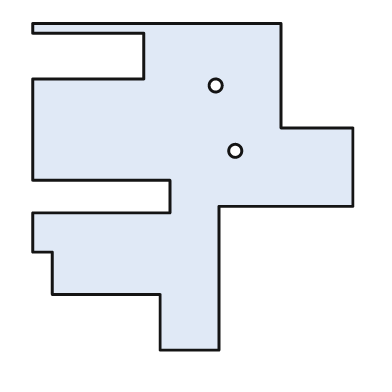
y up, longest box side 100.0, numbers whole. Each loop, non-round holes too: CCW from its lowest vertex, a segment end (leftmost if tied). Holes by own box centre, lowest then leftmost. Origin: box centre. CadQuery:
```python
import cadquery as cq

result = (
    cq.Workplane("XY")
    .moveTo(-10.0, -50.0)
    .lineTo(8.0, -50.0)
    .lineTo(8.0, -6.0)
    .lineTo(49.0, -6.0)
    .lineTo(49.0, 18.0)
    .lineTo(27.0, 18.0)
    .lineTo(27.0, 50.0)
    .lineTo(-49.0, 50.0)
    .lineTo(-49.0, 47.0)
    .lineTo(-15.0, 47.0)
    .lineTo(-15.0, 33.0)
    .lineTo(-49.0, 33.0)
    .lineTo(-49.0, 2.0)
    .lineTo(-7.0, 2.0)
    .lineTo(-7.0, -8.0)
    .lineTo(-49.0, -8.0)
    .lineTo(-49.0, -20.0)
    .lineTo(-43.0, -20.0)
    .lineTo(-43.0, -33.0)
    .lineTo(-10.0, -33.0)
    .close()
    .moveTo(13.0, 11.0)
    .circle(2.0)
    .moveTo(7.0, 31.0)
    .circle(2.0)
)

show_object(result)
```